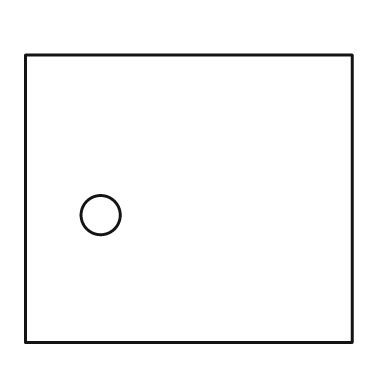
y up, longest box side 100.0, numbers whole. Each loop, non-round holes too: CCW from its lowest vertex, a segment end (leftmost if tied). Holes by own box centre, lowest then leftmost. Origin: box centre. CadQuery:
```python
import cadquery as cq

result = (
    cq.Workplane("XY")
    .moveTo(-50.0, -44.0)
    .lineTo(50.0, -44.0)
    .lineTo(50.0, 44.0)
    .lineTo(-50.0, 44.0)
    .close()
    .moveTo(-27.0, -5.0)
    .circle(6.0)
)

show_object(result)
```